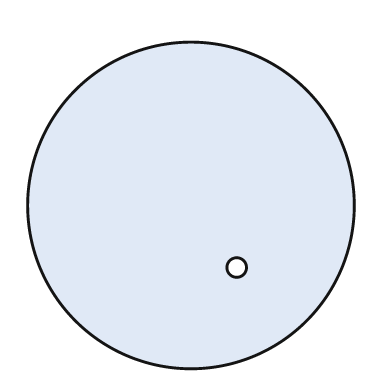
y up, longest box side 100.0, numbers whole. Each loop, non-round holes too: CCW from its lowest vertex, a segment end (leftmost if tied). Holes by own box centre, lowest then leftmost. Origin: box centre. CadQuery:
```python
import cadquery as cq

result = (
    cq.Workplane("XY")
    .moveTo(0.0, 0.0)
    .circle(50.0)
    .moveTo(14.0, -19.0)
    .circle(3.0)
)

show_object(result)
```